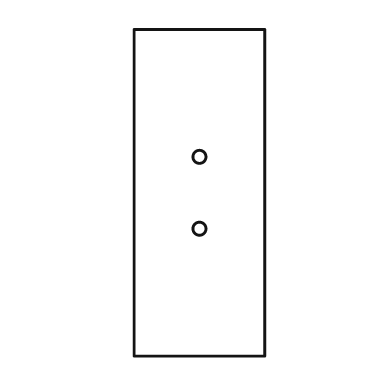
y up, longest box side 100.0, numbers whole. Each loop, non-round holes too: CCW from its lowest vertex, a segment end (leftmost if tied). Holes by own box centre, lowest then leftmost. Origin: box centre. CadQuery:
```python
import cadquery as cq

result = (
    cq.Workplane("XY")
    .moveTo(-20.0, -50.0)
    .lineTo(20.0, -50.0)
    .lineTo(20.0, 50.0)
    .lineTo(-20.0, 50.0)
    .close()
    .moveTo(0.0, -11.0)
    .circle(2.0)
    .moveTo(0.0, 11.0)
    .circle(2.0)
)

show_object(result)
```